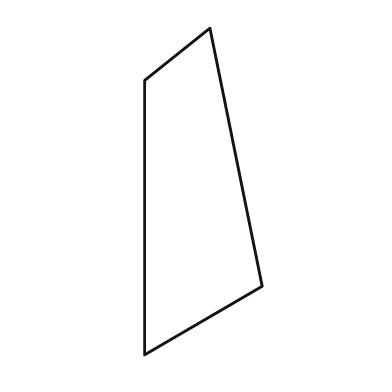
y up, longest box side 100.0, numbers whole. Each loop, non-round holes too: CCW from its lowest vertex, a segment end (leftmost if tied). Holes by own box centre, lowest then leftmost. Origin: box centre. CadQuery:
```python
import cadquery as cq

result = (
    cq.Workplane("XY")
    .moveTo(-18.0, -50.0)
    .lineTo(18.0, -29.0)
    .lineTo(2.0, 50.0)
    .lineTo(-18.0, 34.0)
    .close()
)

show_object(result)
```